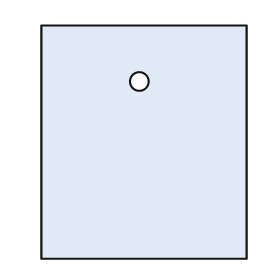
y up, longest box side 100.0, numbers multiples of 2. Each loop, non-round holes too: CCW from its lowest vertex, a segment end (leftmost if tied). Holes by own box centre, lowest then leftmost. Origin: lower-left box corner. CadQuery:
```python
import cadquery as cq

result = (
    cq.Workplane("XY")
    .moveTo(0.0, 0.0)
    .lineTo(88.0, 0.0)
    .lineTo(88.0, 100.0)
    .lineTo(0.0, 100.0)
    .close()
    .moveTo(42.0, 76.0)
    .circle(4.0)
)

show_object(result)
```